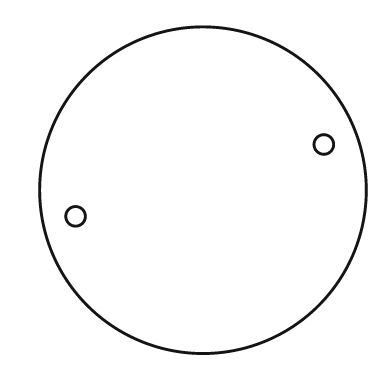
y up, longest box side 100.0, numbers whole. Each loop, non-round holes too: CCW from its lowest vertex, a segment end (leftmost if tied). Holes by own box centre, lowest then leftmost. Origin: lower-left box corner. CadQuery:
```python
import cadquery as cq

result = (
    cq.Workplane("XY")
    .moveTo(50.0, 50.0)
    .circle(50.0)
    .moveTo(11.0, 42.0)
    .circle(3.0)
    .moveTo(87.0, 64.0)
    .circle(3.0)
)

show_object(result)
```